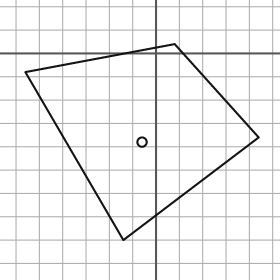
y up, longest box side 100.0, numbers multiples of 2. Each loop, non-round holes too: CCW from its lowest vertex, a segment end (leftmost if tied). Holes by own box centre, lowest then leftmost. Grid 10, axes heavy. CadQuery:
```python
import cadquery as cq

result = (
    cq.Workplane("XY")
    .moveTo(-14.0, -80.0)
    .lineTo(44.0, -36.0)
    .lineTo(8.0, 4.0)
    .lineTo(-56.0, -8.0)
    .close()
    .moveTo(-6.0, -38.0)
    .circle(2.0)
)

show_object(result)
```